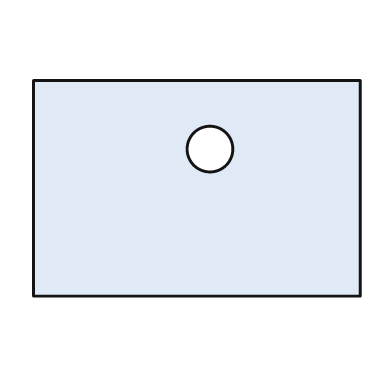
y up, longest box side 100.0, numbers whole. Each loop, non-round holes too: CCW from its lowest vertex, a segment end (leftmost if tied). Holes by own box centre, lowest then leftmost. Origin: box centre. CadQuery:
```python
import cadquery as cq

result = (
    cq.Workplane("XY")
    .moveTo(-50.0, -33.0)
    .lineTo(50.0, -33.0)
    .lineTo(50.0, 33.0)
    .lineTo(-50.0, 33.0)
    .close()
    .moveTo(4.0, 12.0)
    .circle(7.0)
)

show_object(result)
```